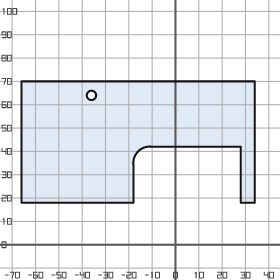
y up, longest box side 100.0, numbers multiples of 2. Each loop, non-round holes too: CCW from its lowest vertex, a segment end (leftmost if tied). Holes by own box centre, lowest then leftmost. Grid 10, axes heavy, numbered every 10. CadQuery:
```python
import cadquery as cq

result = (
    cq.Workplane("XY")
    .moveTo(-66.0, 18.0)
    .lineTo(-18.0, 18.0)
    .lineTo(-18.0, 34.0)
    .threePointArc((-16.0, 40.0), (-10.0, 42.0))
    .lineTo(28.0, 42.0)
    .lineTo(28.0, 18.0)
    .lineTo(34.0, 18.0)
    .lineTo(34.0, 70.0)
    .lineTo(-66.0, 70.0)
    .close()
    .moveTo(-36.0, 64.0)
    .circle(2.0)
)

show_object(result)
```